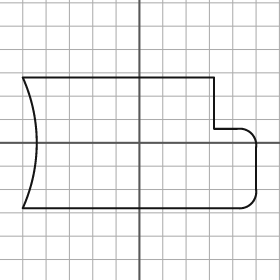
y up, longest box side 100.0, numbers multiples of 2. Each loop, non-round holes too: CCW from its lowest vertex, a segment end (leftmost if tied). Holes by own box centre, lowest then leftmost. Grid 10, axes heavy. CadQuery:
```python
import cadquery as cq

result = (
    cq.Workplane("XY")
    .moveTo(-50.0, -28.0)
    .lineTo(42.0, -28.0)
    .threePointArc((48.0, -26.0), (50.0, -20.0))
    .lineTo(50.0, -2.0)
    .threePointArc((48.0, 4.0), (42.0, 6.0))
    .lineTo(32.0, 6.0)
    .lineTo(32.0, 28.0)
    .lineTo(-50.0, 28.0)
    .threePointArc((-44.0, 0.0), (-50.0, -28.0))
    .close()
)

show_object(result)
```